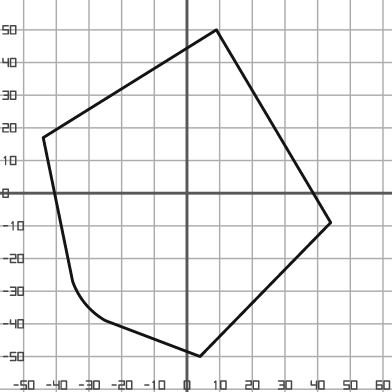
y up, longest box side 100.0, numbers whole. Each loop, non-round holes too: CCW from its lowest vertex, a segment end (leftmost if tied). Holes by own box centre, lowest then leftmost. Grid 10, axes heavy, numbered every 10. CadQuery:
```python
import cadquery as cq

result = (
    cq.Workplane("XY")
    .moveTo(4.0, -50.0)
    .lineTo(44.0, -9.0)
    .lineTo(9.0, 50.0)
    .lineTo(-44.0, 17.0)
    .lineTo(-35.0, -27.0)
    .threePointArc((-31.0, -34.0), (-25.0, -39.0))
    .close()
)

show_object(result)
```